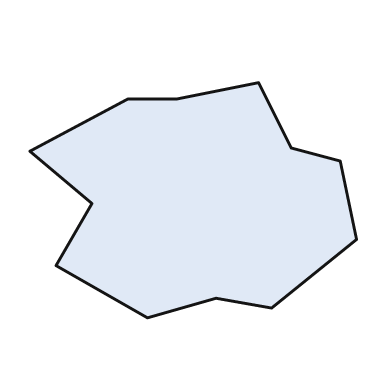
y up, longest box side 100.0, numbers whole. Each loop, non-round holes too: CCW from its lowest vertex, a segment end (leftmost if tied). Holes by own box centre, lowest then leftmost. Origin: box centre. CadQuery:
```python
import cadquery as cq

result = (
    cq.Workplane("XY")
    .moveTo(-14.0, -36.0)
    .lineTo(7.0, -30.0)
    .lineTo(24.0, -33.0)
    .lineTo(50.0, -12.0)
    .lineTo(45.0, 12.0)
    .lineTo(30.0, 16.0)
    .lineTo(20.0, 36.0)
    .lineTo(-5.0, 31.0)
    .lineTo(-20.0, 31.0)
    .lineTo(-50.0, 15.0)
    .lineTo(-31.0, -1.0)
    .lineTo(-42.0, -20.0)
    .close()
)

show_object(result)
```